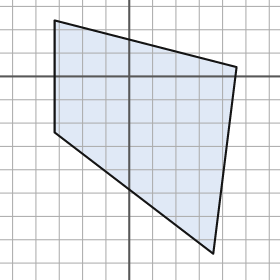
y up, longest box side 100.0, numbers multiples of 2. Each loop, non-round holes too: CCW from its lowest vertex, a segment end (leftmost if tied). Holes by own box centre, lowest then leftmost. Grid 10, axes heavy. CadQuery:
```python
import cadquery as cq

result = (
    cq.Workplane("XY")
    .moveTo(36.0, -76.0)
    .lineTo(46.0, 4.0)
    .lineTo(-32.0, 24.0)
    .lineTo(-32.0, -24.0)
    .close()
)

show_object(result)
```